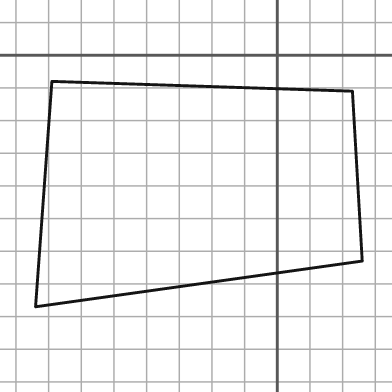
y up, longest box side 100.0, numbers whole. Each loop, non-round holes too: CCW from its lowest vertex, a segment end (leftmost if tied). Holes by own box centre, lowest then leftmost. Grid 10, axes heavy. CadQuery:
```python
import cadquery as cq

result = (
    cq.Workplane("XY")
    .moveTo(-74.0, -77.0)
    .lineTo(26.0, -63.0)
    .lineTo(23.0, -11.0)
    .lineTo(-69.0, -8.0)
    .close()
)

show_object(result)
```